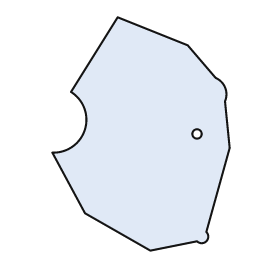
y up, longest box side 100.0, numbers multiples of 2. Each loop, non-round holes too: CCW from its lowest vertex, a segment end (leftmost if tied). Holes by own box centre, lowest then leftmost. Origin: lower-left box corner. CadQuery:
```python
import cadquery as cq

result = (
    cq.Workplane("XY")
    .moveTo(42.0, 0.0)
    .lineTo(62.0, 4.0)
    .threePointArc((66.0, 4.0), (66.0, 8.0))
    .lineTo(76.0, 44.0)
    .lineTo(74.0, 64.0)
    .threePointArc((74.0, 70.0), (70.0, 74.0))
    .lineTo(58.0, 88.0)
    .lineTo(28.0, 100.0)
    .lineTo(8.0, 68.0)
    .threePointArc((14.0, 52.0), (0.0, 42.0))
    .lineTo(14.0, 16.0)
    .close()
    .moveTo(62.0, 50.0)
    .circle(2.0)
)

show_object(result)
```